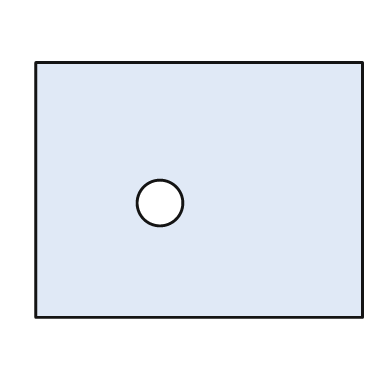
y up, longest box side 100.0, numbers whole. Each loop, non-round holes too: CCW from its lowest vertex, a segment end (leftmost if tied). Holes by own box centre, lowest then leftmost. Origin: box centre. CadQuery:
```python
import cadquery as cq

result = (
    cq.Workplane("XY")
    .moveTo(-50.0, -39.0)
    .lineTo(50.0, -39.0)
    .lineTo(50.0, 39.0)
    .lineTo(-50.0, 39.0)
    .close()
    .moveTo(-12.0, -4.0)
    .circle(7.0)
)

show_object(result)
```